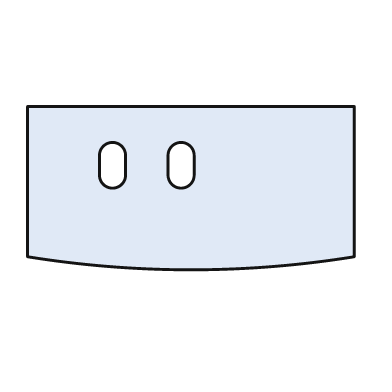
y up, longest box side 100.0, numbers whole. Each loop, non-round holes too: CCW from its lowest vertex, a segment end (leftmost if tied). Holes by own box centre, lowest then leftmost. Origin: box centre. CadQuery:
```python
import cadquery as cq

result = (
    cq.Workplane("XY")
    .moveTo(-50.0, -21.0)
    .threePointArc((0.0, -25.0), (50.0, -21.0))
    .lineTo(50.0, 25.0)
    .lineTo(-50.0, 25.0)
    .close()
    .moveTo(-28.0, 4.0)
    .threePointArc((-24.0, 0.0), (-20.0, 4.0))
    .lineTo(-20.0, 10.0)
    .threePointArc((-24.0, 14.0), (-28.0, 10.0))
    .close()
    .moveTo(-7.0, 4.0)
    .threePointArc((-3.0, 0.0), (1.0, 4.0))
    .lineTo(1.0, 10.0)
    .threePointArc((-3.0, 14.0), (-7.0, 10.0))
    .close()
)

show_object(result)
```